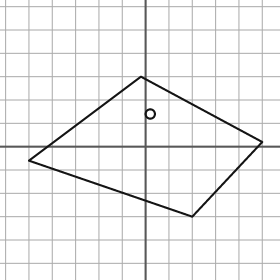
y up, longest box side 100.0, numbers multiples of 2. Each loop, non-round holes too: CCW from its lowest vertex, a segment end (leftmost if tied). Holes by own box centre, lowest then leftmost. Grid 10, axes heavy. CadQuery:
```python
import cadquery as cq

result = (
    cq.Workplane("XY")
    .moveTo(20.0, -30.0)
    .lineTo(50.0, 2.0)
    .lineTo(-2.0, 30.0)
    .lineTo(-50.0, -6.0)
    .close()
    .moveTo(2.0, 14.0)
    .circle(2.0)
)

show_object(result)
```